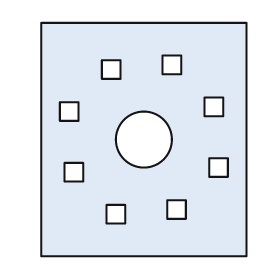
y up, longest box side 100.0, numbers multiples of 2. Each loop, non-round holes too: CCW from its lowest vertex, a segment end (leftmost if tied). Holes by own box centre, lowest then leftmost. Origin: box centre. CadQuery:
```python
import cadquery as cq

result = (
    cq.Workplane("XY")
    .moveTo(-44.0, -50.0)
    .lineTo(44.0, -50.0)
    .lineTo(44.0, 50.0)
    .lineTo(-44.0, 50.0)
    .close()
    .moveTo(-16.0, -36.0)
    .lineTo(-8.0, -36.0)
    .lineTo(-8.0, -28.0)
    .lineTo(-16.0, -28.0)
    .close()
    .moveTo(10.0, -34.0)
    .lineTo(18.0, -34.0)
    .lineTo(18.0, -26.0)
    .lineTo(10.0, -26.0)
    .close()
    .moveTo(-34.0, -18.0)
    .lineTo(-26.0, -18.0)
    .lineTo(-26.0, -10.0)
    .lineTo(-34.0, -10.0)
    .close()
    .moveTo(28.0, -16.0)
    .lineTo(36.0, -16.0)
    .lineTo(36.0, -8.0)
    .lineTo(28.0, -8.0)
    .close()
    .moveTo(0.0, 0.0)
    .circle(12.0)
    .moveTo(-36.0, 8.0)
    .lineTo(-28.0, 8.0)
    .lineTo(-28.0, 16.0)
    .lineTo(-36.0, 16.0)
    .close()
    .moveTo(26.0, 10.0)
    .lineTo(34.0, 10.0)
    .lineTo(34.0, 18.0)
    .lineTo(26.0, 18.0)
    .close()
    .moveTo(-18.0, 26.0)
    .lineTo(-10.0, 26.0)
    .lineTo(-10.0, 34.0)
    .lineTo(-18.0, 34.0)
    .close()
    .moveTo(8.0, 28.0)
    .lineTo(16.0, 28.0)
    .lineTo(16.0, 36.0)
    .lineTo(8.0, 36.0)
    .close()
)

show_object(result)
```